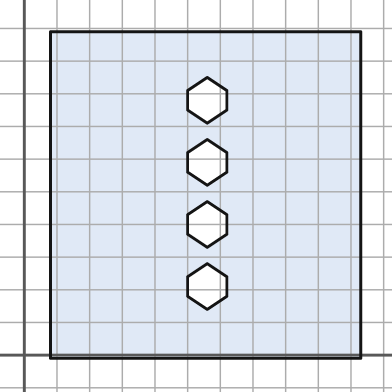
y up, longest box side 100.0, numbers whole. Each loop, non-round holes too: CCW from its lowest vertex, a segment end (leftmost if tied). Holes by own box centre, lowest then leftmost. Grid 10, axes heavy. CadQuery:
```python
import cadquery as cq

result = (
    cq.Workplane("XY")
    .moveTo(8.0, -1.0)
    .lineTo(103.0, -1.0)
    .lineTo(103.0, 99.0)
    .lineTo(8.0, 99.0)
    .close()
    .moveTo(56.0, 14.0)
    .lineTo(62.0, 18.0)
    .lineTo(62.0, 24.0)
    .lineTo(56.0, 28.0)
    .lineTo(50.0, 24.0)
    .lineTo(50.0, 18.0)
    .close()
    .moveTo(56.0, 33.0)
    .lineTo(62.0, 37.0)
    .lineTo(62.0, 43.0)
    .lineTo(56.0, 47.0)
    .lineTo(50.0, 43.0)
    .lineTo(50.0, 37.0)
    .close()
    .moveTo(56.0, 52.0)
    .lineTo(62.0, 56.0)
    .lineTo(62.0, 62.0)
    .lineTo(56.0, 66.0)
    .lineTo(50.0, 62.0)
    .lineTo(50.0, 56.0)
    .close()
    .moveTo(56.0, 71.0)
    .lineTo(62.0, 75.0)
    .lineTo(62.0, 81.0)
    .lineTo(56.0, 85.0)
    .lineTo(50.0, 81.0)
    .lineTo(50.0, 75.0)
    .close()
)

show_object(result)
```